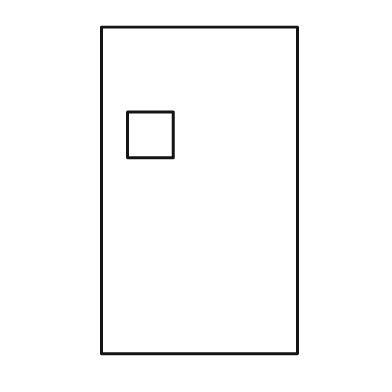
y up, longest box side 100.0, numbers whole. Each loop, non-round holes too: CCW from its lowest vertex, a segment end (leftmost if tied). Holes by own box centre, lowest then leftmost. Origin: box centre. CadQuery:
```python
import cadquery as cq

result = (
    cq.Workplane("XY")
    .moveTo(-30.0, -50.0)
    .lineTo(30.0, -50.0)
    .lineTo(30.0, 50.0)
    .lineTo(-30.0, 50.0)
    .close()
    .moveTo(-22.0, 10.0)
    .lineTo(-8.0, 10.0)
    .lineTo(-8.0, 24.0)
    .lineTo(-22.0, 24.0)
    .close()
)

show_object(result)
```